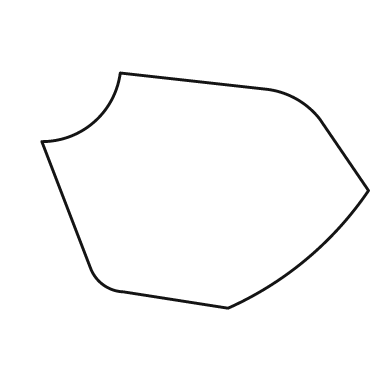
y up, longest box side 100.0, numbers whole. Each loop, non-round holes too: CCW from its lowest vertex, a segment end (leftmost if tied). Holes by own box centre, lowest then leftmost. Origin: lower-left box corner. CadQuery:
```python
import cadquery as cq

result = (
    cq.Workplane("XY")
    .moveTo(57.0, 0.0)
    .threePointArc((81.0, 15.0), (100.0, 36.0))
    .lineTo(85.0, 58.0)
    .threePointArc((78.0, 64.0), (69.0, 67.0))
    .lineTo(24.0, 72.0)
    .threePointArc((16.0, 57.0), (0.0, 51.0))
    .lineTo(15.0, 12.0)
    .threePointArc((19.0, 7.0), (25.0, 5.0))
    .close()
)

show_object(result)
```